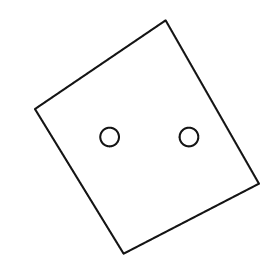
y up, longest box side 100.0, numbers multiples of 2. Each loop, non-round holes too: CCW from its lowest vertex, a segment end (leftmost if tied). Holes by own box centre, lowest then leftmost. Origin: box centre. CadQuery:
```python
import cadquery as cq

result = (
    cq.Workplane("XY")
    .moveTo(-10.0, -50.0)
    .lineTo(48.0, -20.0)
    .lineTo(8.0, 50.0)
    .lineTo(-48.0, 12.0)
    .close()
    .moveTo(-16.0, 0.0)
    .circle(4.0)
    .moveTo(18.0, 0.0)
    .circle(4.0)
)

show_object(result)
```